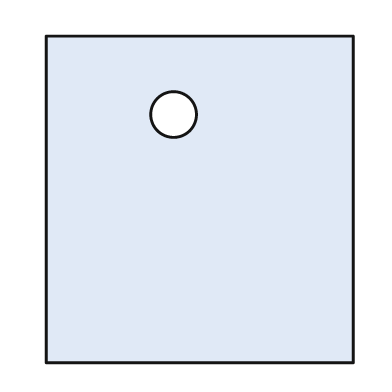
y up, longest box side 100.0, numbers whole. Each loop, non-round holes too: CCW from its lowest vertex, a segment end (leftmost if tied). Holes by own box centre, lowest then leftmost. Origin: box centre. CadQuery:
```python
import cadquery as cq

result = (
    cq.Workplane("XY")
    .moveTo(-47.0, -50.0)
    .lineTo(47.0, -50.0)
    .lineTo(47.0, 50.0)
    .lineTo(-47.0, 50.0)
    .close()
    .moveTo(-8.0, 26.0)
    .circle(7.0)
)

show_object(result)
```